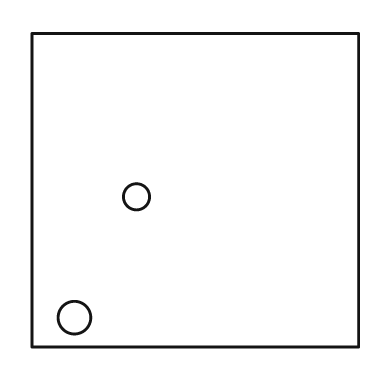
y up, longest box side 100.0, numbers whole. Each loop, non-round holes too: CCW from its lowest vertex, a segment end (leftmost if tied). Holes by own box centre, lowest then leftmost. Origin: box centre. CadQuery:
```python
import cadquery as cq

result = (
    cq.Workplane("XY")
    .moveTo(-50.0, -48.0)
    .lineTo(50.0, -48.0)
    .lineTo(50.0, 48.0)
    .lineTo(-50.0, 48.0)
    .close()
    .moveTo(-37.0, -39.0)
    .circle(5.0)
    .moveTo(-18.0, -2.0)
    .circle(4.0)
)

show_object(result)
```